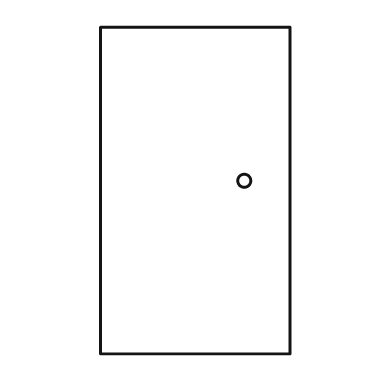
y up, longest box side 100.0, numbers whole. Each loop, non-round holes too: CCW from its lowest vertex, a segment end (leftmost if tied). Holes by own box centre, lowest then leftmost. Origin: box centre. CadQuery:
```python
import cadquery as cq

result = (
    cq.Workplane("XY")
    .moveTo(-29.0, -50.0)
    .lineTo(29.0, -50.0)
    .lineTo(29.0, 50.0)
    .lineTo(-29.0, 50.0)
    .close()
    .moveTo(15.0, 3.0)
    .circle(2.0)
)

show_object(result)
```